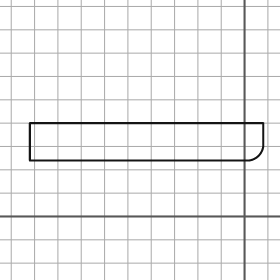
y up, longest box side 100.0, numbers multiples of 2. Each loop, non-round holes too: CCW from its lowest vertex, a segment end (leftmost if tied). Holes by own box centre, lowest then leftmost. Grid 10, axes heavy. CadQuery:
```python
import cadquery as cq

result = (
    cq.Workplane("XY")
    .moveTo(-92.0, 24.0)
    .lineTo(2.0, 24.0)
    .threePointArc((6.0, 26.0), (8.0, 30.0))
    .lineTo(8.0, 40.0)
    .lineTo(-92.0, 40.0)
    .close()
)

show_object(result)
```